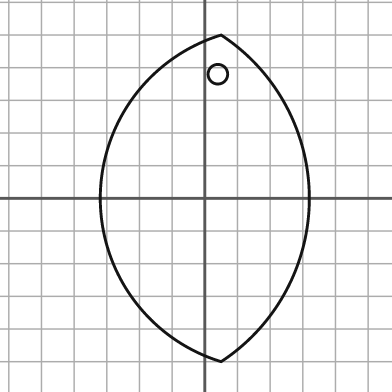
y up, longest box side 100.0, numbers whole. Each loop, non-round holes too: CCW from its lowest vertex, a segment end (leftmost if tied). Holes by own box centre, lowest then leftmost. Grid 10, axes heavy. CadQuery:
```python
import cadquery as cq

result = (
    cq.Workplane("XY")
    .moveTo(5.0, -50.0)
    .threePointArc((32.0, 0.0), (5.0, 50.0))
    .threePointArc((-32.0, 0.0), (5.0, -50.0))
    .close()
    .moveTo(4.0, 38.0)
    .circle(3.0)
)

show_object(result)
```